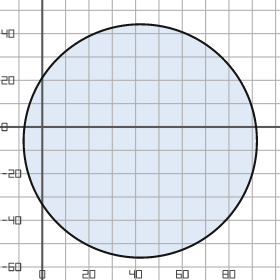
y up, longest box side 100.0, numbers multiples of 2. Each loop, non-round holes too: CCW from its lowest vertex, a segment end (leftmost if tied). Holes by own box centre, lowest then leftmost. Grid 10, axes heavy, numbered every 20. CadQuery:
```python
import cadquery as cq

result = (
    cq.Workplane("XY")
    .moveTo(42.0, -6.0)
    .circle(50.0)
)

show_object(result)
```